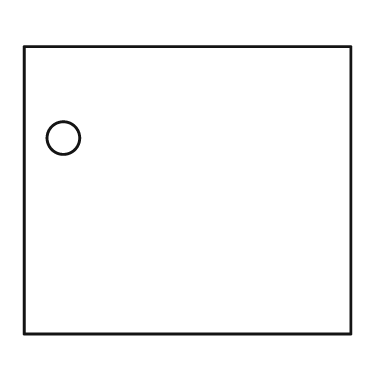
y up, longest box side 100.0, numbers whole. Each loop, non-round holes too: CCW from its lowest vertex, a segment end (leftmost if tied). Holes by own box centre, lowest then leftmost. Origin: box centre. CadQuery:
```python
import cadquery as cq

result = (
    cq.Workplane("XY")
    .moveTo(-50.0, -44.0)
    .lineTo(50.0, -44.0)
    .lineTo(50.0, 44.0)
    .lineTo(-50.0, 44.0)
    .close()
    .moveTo(-38.0, 16.0)
    .circle(5.0)
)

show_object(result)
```